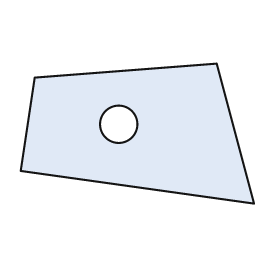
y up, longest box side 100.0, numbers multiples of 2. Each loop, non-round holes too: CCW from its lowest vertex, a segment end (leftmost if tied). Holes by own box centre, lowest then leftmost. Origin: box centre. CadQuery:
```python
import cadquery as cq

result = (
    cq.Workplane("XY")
    .moveTo(50.0, -30.0)
    .lineTo(34.0, 30.0)
    .lineTo(-44.0, 24.0)
    .lineTo(-50.0, -16.0)
    .close()
    .moveTo(-8.0, 4.0)
    .circle(8.0)
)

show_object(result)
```